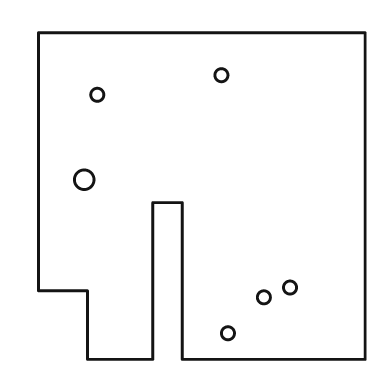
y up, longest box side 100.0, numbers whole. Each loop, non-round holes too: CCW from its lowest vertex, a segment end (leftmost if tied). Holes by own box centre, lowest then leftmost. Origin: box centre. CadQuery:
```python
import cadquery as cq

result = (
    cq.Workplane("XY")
    .moveTo(-35.0, -50.0)
    .lineTo(-15.0, -50.0)
    .lineTo(-15.0, -2.0)
    .lineTo(-6.0, -2.0)
    .lineTo(-6.0, -50.0)
    .lineTo(50.0, -50.0)
    .lineTo(50.0, 50.0)
    .lineTo(-50.0, 50.0)
    .lineTo(-50.0, -29.0)
    .lineTo(-35.0, -29.0)
    .close()
    .moveTo(8.0, -42.0)
    .circle(2.0)
    .moveTo(19.0, -31.0)
    .circle(2.0)
    .moveTo(27.0, -28.0)
    .circle(2.0)
    .moveTo(-36.0, 5.0)
    .circle(3.0)
    .moveTo(-32.0, 31.0)
    .circle(2.0)
    .moveTo(6.0, 37.0)
    .circle(2.0)
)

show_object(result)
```